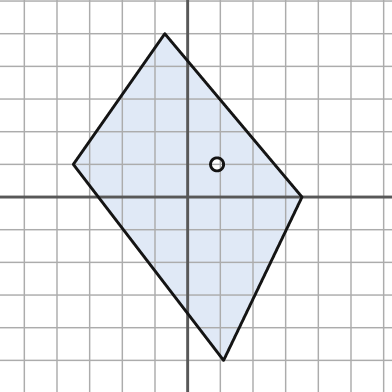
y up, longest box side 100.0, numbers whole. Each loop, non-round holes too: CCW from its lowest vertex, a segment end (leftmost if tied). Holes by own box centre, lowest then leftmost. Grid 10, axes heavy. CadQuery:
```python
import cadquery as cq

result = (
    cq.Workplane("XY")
    .moveTo(11.0, -50.0)
    .lineTo(35.0, 0.0)
    .lineTo(-7.0, 50.0)
    .lineTo(-35.0, 10.0)
    .close()
    .moveTo(9.0, 10.0)
    .circle(2.0)
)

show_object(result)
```